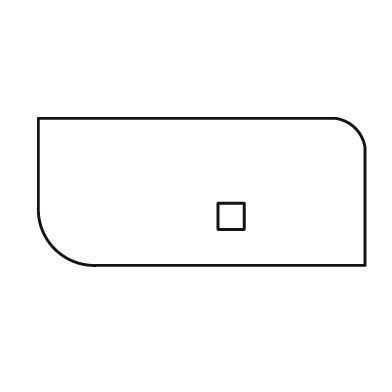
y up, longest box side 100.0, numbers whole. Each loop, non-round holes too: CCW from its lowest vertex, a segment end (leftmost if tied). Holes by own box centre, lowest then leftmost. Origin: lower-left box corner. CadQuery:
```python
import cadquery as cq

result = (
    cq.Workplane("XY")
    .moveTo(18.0, 0.0)
    .lineTo(100.0, 0.0)
    .lineTo(100.0, 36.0)
    .threePointArc((97.0, 42.0), (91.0, 45.0))
    .lineTo(0.0, 45.0)
    .lineTo(0.0, 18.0)
    .threePointArc((5.0, 5.0), (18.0, 0.0))
    .close()
    .moveTo(55.0, 11.0)
    .lineTo(63.0, 11.0)
    .lineTo(63.0, 19.0)
    .lineTo(55.0, 19.0)
    .close()
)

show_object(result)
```